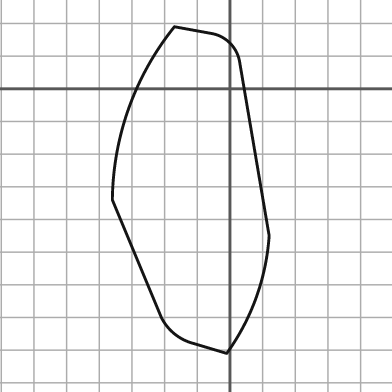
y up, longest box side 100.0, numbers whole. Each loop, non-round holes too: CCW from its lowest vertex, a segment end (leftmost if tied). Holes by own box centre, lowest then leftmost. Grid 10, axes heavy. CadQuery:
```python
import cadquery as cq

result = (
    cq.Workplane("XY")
    .moveTo(-1.0, -81.0)
    .threePointArc((8.0, -64.0), (12.0, -45.0))
    .lineTo(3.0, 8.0)
    .threePointArc((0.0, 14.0), (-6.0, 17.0))
    .lineTo(-17.0, 19.0)
    .threePointArc((-31.0, -6.0), (-36.0, -34.0))
    .lineTo(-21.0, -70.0)
    .threePointArc((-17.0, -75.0), (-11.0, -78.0))
    .close()
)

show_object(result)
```